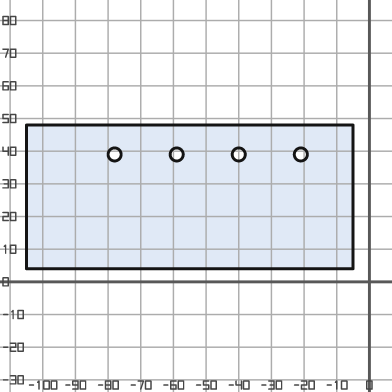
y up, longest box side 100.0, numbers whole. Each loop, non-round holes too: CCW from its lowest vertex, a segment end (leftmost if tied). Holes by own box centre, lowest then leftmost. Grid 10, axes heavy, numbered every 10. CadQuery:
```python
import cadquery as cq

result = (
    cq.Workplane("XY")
    .moveTo(-105.0, 4.0)
    .lineTo(-5.0, 4.0)
    .lineTo(-5.0, 48.0)
    .lineTo(-105.0, 48.0)
    .close()
    .moveTo(-78.0, 39.0)
    .circle(2.0)
    .moveTo(-59.0, 39.0)
    .circle(2.0)
    .moveTo(-40.0, 39.0)
    .circle(2.0)
    .moveTo(-21.0, 39.0)
    .circle(2.0)
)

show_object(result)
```